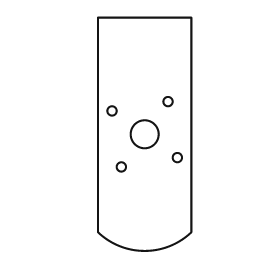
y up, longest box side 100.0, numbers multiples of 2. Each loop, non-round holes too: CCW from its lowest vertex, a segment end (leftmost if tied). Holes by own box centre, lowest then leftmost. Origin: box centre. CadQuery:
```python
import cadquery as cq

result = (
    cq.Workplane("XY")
    .moveTo(-20.0, -42.0)
    .threePointArc((0.0, -50.0), (20.0, -42.0))
    .lineTo(20.0, 50.0)
    .lineTo(-20.0, 50.0)
    .close()
    .moveTo(-10.0, -14.0)
    .circle(2.0)
    .moveTo(14.0, -10.0)
    .circle(2.0)
    .moveTo(0.0, 0.0)
    .circle(6.0)
    .moveTo(-14.0, 10.0)
    .circle(2.0)
    .moveTo(10.0, 14.0)
    .circle(2.0)
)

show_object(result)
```